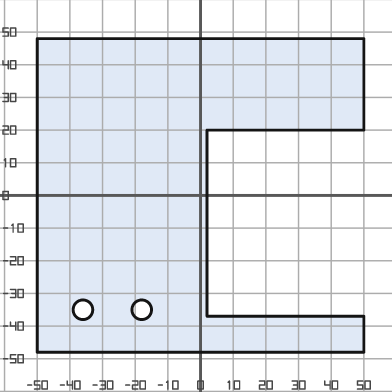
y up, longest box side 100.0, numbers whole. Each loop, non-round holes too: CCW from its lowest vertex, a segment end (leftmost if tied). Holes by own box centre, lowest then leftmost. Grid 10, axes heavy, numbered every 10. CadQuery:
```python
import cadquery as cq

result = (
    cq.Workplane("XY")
    .moveTo(-50.0, -48.0)
    .lineTo(50.0, -48.0)
    .lineTo(50.0, -37.0)
    .lineTo(2.0, -37.0)
    .lineTo(2.0, 20.0)
    .lineTo(50.0, 20.0)
    .lineTo(50.0, 48.0)
    .lineTo(-50.0, 48.0)
    .close()
    .moveTo(-36.0, -35.0)
    .circle(3.0)
    .moveTo(-18.0, -35.0)
    .circle(3.0)
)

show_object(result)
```